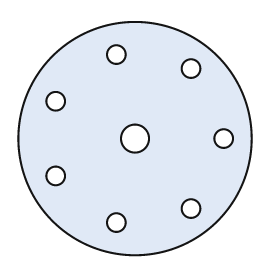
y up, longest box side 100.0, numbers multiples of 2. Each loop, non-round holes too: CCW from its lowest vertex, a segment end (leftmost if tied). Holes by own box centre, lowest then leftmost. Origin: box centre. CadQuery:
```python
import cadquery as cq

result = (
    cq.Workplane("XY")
    .moveTo(0.0, 0.0)
    .circle(50.0)
    .moveTo(-8.0, -36.0)
    .circle(4.0)
    .moveTo(24.0, -30.0)
    .circle(4.0)
    .moveTo(-34.0, -16.0)
    .circle(4.0)
    .moveTo(0.0, 0.0)
    .circle(6.0)
    .moveTo(38.0, 0.0)
    .circle(4.0)
    .moveTo(-34.0, 16.0)
    .circle(4.0)
    .moveTo(24.0, 30.0)
    .circle(4.0)
    .moveTo(-8.0, 36.0)
    .circle(4.0)
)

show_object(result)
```